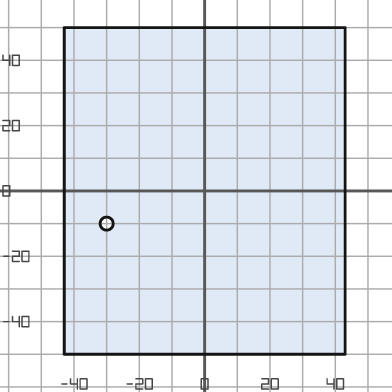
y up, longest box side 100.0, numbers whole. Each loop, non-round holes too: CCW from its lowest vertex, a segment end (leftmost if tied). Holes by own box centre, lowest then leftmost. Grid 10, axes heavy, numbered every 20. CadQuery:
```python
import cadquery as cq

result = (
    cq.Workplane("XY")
    .moveTo(-43.0, -50.0)
    .lineTo(43.0, -50.0)
    .lineTo(43.0, 50.0)
    .lineTo(-43.0, 50.0)
    .close()
    .moveTo(-30.0, -10.0)
    .circle(2.0)
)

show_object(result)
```